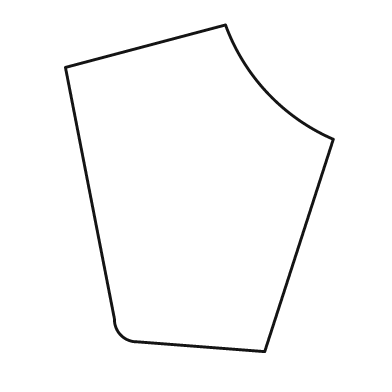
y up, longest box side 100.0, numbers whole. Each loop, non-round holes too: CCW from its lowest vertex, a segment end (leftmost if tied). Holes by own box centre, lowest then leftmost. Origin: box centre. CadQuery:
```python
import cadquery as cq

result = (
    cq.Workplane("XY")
    .moveTo(20.0, -50.0)
    .lineTo(41.0, 15.0)
    .threePointArc((21.0, 29.0), (8.0, 50.0))
    .lineTo(-41.0, 37.0)
    .lineTo(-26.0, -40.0)
    .threePointArc((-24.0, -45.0), (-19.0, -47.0))
    .close()
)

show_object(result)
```